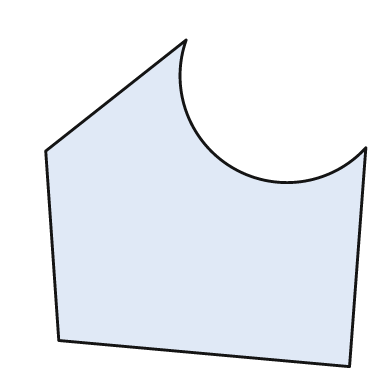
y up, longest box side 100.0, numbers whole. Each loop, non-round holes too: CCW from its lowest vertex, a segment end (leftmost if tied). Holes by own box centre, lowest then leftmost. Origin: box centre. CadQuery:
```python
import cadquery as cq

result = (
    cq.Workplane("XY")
    .moveTo(44.0, -50.0)
    .lineTo(49.0, 17.0)
    .threePointArc((8.0, 11.0), (-6.0, 50.0))
    .lineTo(-49.0, 16.0)
    .lineTo(-45.0, -42.0)
    .close()
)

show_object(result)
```